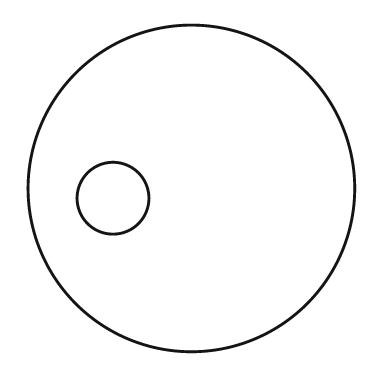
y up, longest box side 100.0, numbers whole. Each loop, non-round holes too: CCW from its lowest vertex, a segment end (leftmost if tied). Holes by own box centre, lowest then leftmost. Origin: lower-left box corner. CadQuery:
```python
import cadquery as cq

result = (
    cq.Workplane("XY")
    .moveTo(50.0, 50.0)
    .circle(50.0)
    .moveTo(26.0, 47.0)
    .circle(11.0)
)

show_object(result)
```